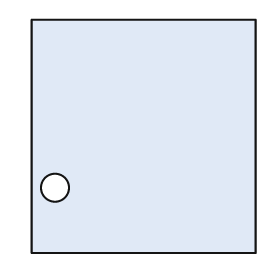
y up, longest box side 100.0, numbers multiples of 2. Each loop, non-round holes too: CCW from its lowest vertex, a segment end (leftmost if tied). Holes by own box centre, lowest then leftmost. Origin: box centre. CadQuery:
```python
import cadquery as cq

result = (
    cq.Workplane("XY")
    .moveTo(-48.0, -50.0)
    .lineTo(48.0, -50.0)
    .lineTo(48.0, 50.0)
    .lineTo(-48.0, 50.0)
    .close()
    .moveTo(-38.0, -22.0)
    .circle(6.0)
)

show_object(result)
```